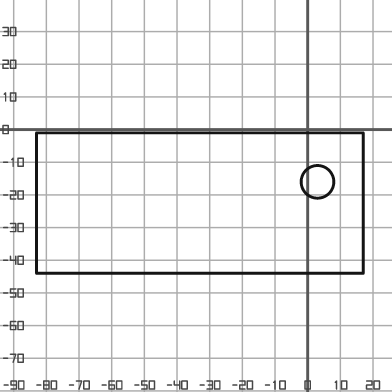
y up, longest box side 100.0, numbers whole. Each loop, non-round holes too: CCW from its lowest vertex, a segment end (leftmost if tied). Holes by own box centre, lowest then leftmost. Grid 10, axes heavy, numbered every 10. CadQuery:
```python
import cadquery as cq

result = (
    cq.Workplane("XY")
    .moveTo(-83.0, -44.0)
    .lineTo(17.0, -44.0)
    .lineTo(17.0, -1.0)
    .lineTo(-83.0, -1.0)
    .close()
    .moveTo(3.0, -16.0)
    .circle(5.0)
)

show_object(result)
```